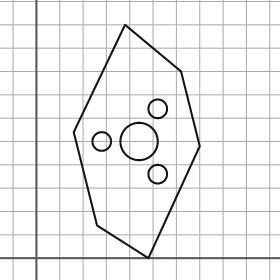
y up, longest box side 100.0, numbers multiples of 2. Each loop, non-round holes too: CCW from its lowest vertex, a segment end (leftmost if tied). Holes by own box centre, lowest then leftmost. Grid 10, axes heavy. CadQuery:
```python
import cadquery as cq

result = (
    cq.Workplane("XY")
    .moveTo(48.0, 0.0)
    .lineTo(70.0, 48.0)
    .lineTo(62.0, 80.0)
    .lineTo(38.0, 100.0)
    .lineTo(16.0, 54.0)
    .lineTo(26.0, 14.0)
    .close()
    .moveTo(52.0, 36.0)
    .circle(4.0)
    .moveTo(28.0, 50.0)
    .circle(4.0)
    .moveTo(44.0, 50.0)
    .circle(8.0)
    .moveTo(52.0, 64.0)
    .circle(4.0)
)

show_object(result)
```